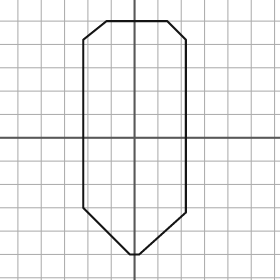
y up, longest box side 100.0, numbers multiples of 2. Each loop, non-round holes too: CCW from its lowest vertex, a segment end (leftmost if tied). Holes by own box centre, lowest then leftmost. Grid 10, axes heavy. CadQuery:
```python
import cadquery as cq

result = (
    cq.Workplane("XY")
    .moveTo(-2.0, -50.0)
    .lineTo(2.0, -50.0)
    .lineTo(22.0, -32.0)
    .lineTo(22.0, 42.0)
    .lineTo(14.0, 50.0)
    .lineTo(-12.0, 50.0)
    .lineTo(-22.0, 42.0)
    .lineTo(-22.0, -30.0)
    .close()
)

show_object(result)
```